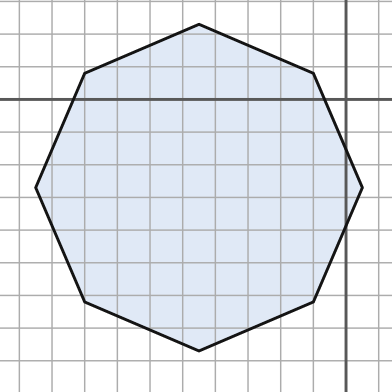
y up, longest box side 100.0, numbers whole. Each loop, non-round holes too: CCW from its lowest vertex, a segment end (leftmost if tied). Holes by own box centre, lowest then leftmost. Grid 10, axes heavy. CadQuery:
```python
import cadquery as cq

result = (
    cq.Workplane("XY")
    .moveTo(-45.0, -77.0)
    .lineTo(-10.0, -62.0)
    .lineTo(5.0, -27.0)
    .lineTo(-10.0, 8.0)
    .lineTo(-45.0, 23.0)
    .lineTo(-80.0, 8.0)
    .lineTo(-95.0, -27.0)
    .lineTo(-80.0, -62.0)
    .close()
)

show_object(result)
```